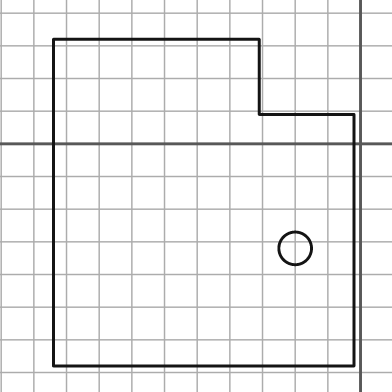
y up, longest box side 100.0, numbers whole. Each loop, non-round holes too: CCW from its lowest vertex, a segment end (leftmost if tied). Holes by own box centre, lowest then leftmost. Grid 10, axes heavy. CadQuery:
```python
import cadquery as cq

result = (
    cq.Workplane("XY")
    .moveTo(-94.0, -68.0)
    .lineTo(-2.0, -68.0)
    .lineTo(-2.0, 9.0)
    .lineTo(-31.0, 9.0)
    .lineTo(-31.0, 32.0)
    .lineTo(-94.0, 32.0)
    .close()
    .moveTo(-20.0, -32.0)
    .circle(5.0)
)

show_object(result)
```